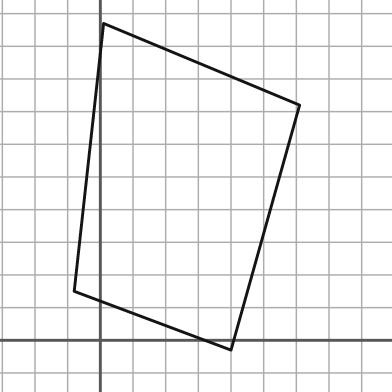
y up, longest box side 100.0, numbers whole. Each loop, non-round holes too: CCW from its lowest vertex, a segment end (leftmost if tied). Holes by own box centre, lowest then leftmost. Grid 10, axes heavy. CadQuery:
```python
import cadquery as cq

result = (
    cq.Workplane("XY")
    .moveTo(40.0, -3.0)
    .lineTo(61.0, 72.0)
    .lineTo(1.0, 97.0)
    .lineTo(-8.0, 15.0)
    .close()
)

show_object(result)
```